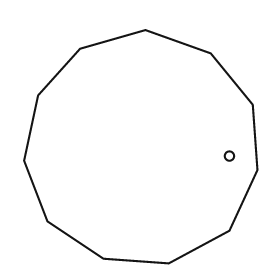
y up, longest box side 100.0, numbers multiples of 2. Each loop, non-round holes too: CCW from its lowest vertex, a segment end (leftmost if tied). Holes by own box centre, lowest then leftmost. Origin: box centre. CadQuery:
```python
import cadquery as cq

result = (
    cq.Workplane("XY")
    .moveTo(12.0, -50.0)
    .lineTo(38.0, -36.0)
    .lineTo(50.0, -10.0)
    .lineTo(48.0, 18.0)
    .lineTo(30.0, 40.0)
    .lineTo(2.0, 50.0)
    .lineTo(-26.0, 42.0)
    .lineTo(-44.0, 22.0)
    .lineTo(-50.0, -6.0)
    .lineTo(-40.0, -32.0)
    .lineTo(-16.0, -48.0)
    .close()
    .moveTo(38.0, -4.0)
    .circle(2.0)
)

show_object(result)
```